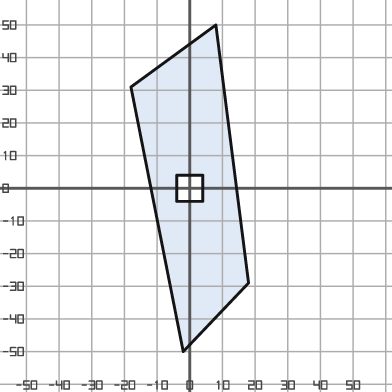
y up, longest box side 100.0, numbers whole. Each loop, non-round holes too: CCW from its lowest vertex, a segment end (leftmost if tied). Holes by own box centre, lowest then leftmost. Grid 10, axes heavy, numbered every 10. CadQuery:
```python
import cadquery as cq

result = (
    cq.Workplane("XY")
    .moveTo(-2.0, -50.0)
    .lineTo(18.0, -29.0)
    .lineTo(8.0, 50.0)
    .lineTo(-18.0, 31.0)
    .close()
    .moveTo(-4.0, -4.0)
    .lineTo(4.0, -4.0)
    .lineTo(4.0, 4.0)
    .lineTo(-4.0, 4.0)
    .close()
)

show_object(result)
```